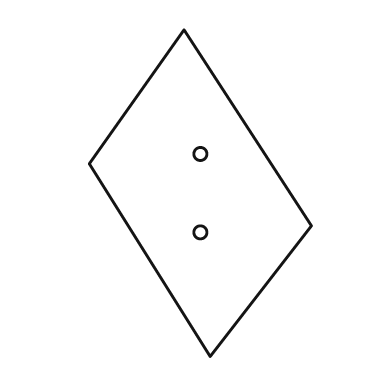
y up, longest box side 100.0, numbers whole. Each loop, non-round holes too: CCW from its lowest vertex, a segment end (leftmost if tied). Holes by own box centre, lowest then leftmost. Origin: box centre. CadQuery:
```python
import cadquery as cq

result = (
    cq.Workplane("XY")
    .moveTo(3.0, -50.0)
    .lineTo(34.0, -10.0)
    .lineTo(-5.0, 50.0)
    .lineTo(-34.0, 9.0)
    .close()
    .moveTo(0.0, -12.0)
    .circle(2.0)
    .moveTo(0.0, 12.0)
    .circle(2.0)
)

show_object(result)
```